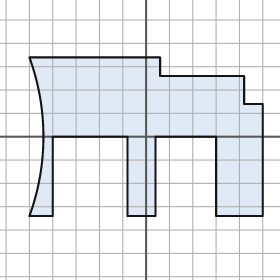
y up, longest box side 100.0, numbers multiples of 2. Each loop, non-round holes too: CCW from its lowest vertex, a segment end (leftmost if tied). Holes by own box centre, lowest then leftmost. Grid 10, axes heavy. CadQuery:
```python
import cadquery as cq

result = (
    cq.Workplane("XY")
    .moveTo(-50.0, -34.0)
    .lineTo(-40.0, -34.0)
    .lineTo(-40.0, 0.0)
    .lineTo(-8.0, 0.0)
    .lineTo(-8.0, -34.0)
    .lineTo(4.0, -34.0)
    .lineTo(4.0, 0.0)
    .lineTo(30.0, 0.0)
    .lineTo(30.0, -34.0)
    .lineTo(50.0, -34.0)
    .lineTo(50.0, 14.0)
    .lineTo(42.0, 14.0)
    .lineTo(42.0, 26.0)
    .lineTo(6.0, 26.0)
    .lineTo(6.0, 34.0)
    .lineTo(-50.0, 34.0)
    .threePointArc((-44.0, 0.0), (-50.0, -34.0))
    .close()
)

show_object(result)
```